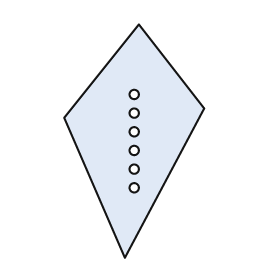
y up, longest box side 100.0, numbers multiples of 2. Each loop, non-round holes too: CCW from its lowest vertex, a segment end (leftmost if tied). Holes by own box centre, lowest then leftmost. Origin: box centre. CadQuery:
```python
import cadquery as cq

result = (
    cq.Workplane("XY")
    .moveTo(-4.0, -50.0)
    .lineTo(30.0, 14.0)
    .lineTo(2.0, 50.0)
    .lineTo(-30.0, 10.0)
    .close()
    .moveTo(0.0, -20.0)
    .circle(2.0)
    .moveTo(0.0, -12.0)
    .circle(2.0)
    .moveTo(0.0, -4.0)
    .circle(2.0)
    .moveTo(0.0, 4.0)
    .circle(2.0)
    .moveTo(0.0, 12.0)
    .circle(2.0)
    .moveTo(0.0, 20.0)
    .circle(2.0)
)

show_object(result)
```